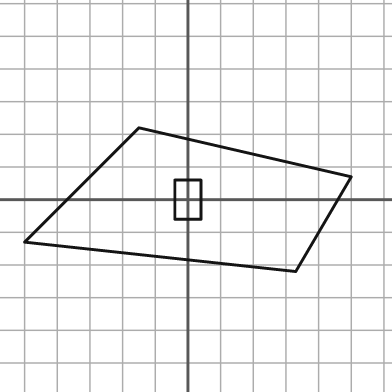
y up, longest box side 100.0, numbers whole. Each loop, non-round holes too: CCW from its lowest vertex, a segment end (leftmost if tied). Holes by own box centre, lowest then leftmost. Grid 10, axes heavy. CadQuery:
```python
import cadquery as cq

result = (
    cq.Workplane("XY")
    .moveTo(33.0, -22.0)
    .lineTo(50.0, 7.0)
    .lineTo(-15.0, 22.0)
    .lineTo(-50.0, -13.0)
    .close()
    .moveTo(-4.0, -6.0)
    .lineTo(4.0, -6.0)
    .lineTo(4.0, 6.0)
    .lineTo(-4.0, 6.0)
    .close()
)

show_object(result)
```